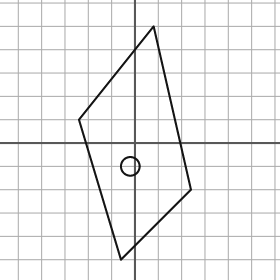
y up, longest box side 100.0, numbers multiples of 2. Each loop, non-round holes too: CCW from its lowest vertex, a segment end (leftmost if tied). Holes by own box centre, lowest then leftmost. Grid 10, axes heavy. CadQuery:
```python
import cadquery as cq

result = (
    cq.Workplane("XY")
    .moveTo(-6.0, -50.0)
    .lineTo(24.0, -20.0)
    .lineTo(8.0, 50.0)
    .lineTo(-24.0, 10.0)
    .close()
    .moveTo(-2.0, -10.0)
    .circle(4.0)
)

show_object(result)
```